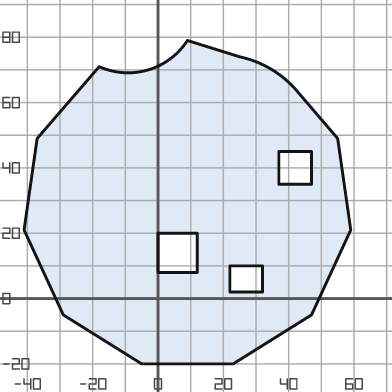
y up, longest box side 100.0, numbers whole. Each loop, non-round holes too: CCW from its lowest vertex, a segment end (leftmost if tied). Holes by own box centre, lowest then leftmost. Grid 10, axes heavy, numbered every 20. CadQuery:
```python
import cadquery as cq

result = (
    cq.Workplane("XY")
    .moveTo(-5.0, -20.0)
    .lineTo(23.0, -20.0)
    .lineTo(47.0, -5.0)
    .lineTo(59.0, 21.0)
    .lineTo(55.0, 49.0)
    .lineTo(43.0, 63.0)
    .threePointArc((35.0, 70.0), (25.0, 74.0))
    .lineTo(9.0, 79.0)
    .threePointArc((-3.0, 70.0), (-18.0, 71.0))
    .lineTo(-37.0, 49.0)
    .lineTo(-41.0, 21.0)
    .lineTo(-29.0, -5.0)
    .close()
    .moveTo(22.0, 2.0)
    .lineTo(32.0, 2.0)
    .lineTo(32.0, 10.0)
    .lineTo(22.0, 10.0)
    .close()
    .moveTo(0.0, 8.0)
    .lineTo(12.0, 8.0)
    .lineTo(12.0, 20.0)
    .lineTo(0.0, 20.0)
    .close()
    .moveTo(37.0, 35.0)
    .lineTo(47.0, 35.0)
    .lineTo(47.0, 45.0)
    .lineTo(37.0, 45.0)
    .close()
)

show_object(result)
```